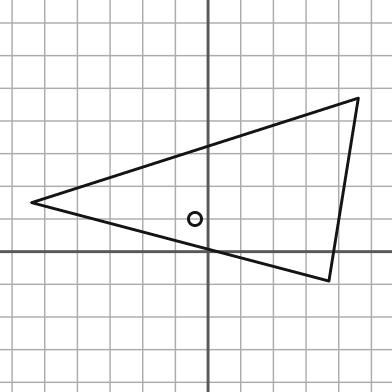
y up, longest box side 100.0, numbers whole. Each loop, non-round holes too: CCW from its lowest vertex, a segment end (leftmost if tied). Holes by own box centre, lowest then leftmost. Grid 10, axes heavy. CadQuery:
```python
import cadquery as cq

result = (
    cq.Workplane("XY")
    .moveTo(37.0, -9.0)
    .lineTo(46.0, 47.0)
    .lineTo(-54.0, 15.0)
    .close()
    .moveTo(-4.0, 10.0)
    .circle(2.0)
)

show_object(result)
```